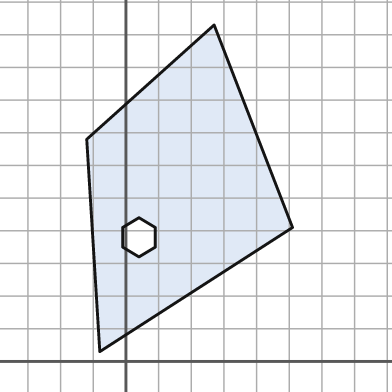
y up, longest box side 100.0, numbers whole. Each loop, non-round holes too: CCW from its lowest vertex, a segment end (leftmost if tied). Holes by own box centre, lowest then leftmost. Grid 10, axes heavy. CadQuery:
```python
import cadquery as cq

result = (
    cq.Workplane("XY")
    .moveTo(-8.0, 3.0)
    .lineTo(51.0, 41.0)
    .lineTo(27.0, 103.0)
    .lineTo(-12.0, 68.0)
    .close()
    .moveTo(4.0, 32.0)
    .lineTo(9.0, 35.0)
    .lineTo(9.0, 41.0)
    .lineTo(4.0, 44.0)
    .lineTo(-1.0, 41.0)
    .lineTo(-1.0, 35.0)
    .close()
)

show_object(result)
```